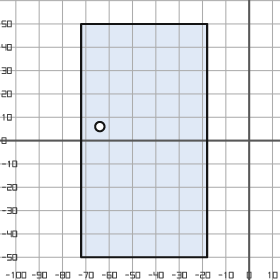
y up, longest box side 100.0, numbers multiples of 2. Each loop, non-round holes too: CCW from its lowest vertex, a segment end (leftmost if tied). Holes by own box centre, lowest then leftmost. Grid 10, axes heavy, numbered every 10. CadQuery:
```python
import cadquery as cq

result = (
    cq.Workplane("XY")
    .moveTo(-72.0, -50.0)
    .lineTo(-18.0, -50.0)
    .lineTo(-18.0, 50.0)
    .lineTo(-72.0, 50.0)
    .close()
    .moveTo(-64.0, 6.0)
    .circle(2.0)
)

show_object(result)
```